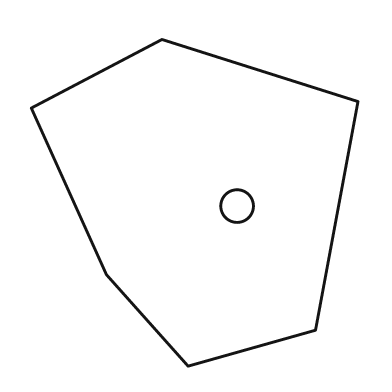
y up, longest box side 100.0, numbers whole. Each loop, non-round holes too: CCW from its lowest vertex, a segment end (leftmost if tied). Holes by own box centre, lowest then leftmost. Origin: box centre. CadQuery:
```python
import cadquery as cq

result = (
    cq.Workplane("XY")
    .moveTo(-2.0, -50.0)
    .lineTo(37.0, -39.0)
    .lineTo(50.0, 31.0)
    .lineTo(-10.0, 50.0)
    .lineTo(-50.0, 29.0)
    .lineTo(-27.0, -22.0)
    .close()
    .moveTo(13.0, -1.0)
    .circle(5.0)
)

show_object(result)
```